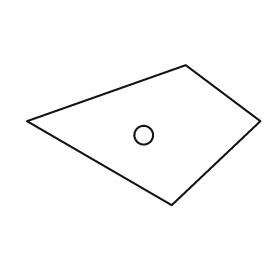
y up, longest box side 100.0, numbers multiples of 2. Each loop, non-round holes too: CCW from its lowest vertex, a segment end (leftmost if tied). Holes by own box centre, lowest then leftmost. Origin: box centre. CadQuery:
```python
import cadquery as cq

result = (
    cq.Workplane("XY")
    .moveTo(12.0, -30.0)
    .lineTo(50.0, 6.0)
    .lineTo(18.0, 30.0)
    .lineTo(-50.0, 6.0)
    .close()
    .moveTo(0.0, 0.0)
    .circle(4.0)
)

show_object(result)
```